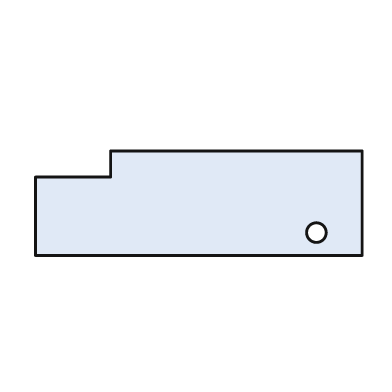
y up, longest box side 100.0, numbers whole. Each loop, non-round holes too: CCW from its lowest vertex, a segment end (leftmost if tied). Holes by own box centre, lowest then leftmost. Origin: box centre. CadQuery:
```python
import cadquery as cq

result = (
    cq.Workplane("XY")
    .moveTo(-50.0, -16.0)
    .lineTo(50.0, -16.0)
    .lineTo(50.0, 16.0)
    .lineTo(-27.0, 16.0)
    .lineTo(-27.0, 8.0)
    .lineTo(-50.0, 8.0)
    .close()
    .moveTo(36.0, -9.0)
    .circle(3.0)
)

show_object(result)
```